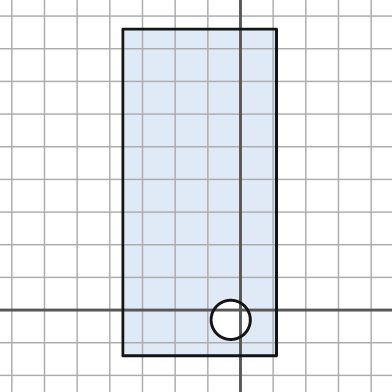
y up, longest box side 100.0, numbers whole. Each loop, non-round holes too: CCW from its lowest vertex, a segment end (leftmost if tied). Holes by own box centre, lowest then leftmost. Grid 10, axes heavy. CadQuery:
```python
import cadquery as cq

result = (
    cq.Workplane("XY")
    .moveTo(-36.0, -14.0)
    .lineTo(11.0, -14.0)
    .lineTo(11.0, 86.0)
    .lineTo(-36.0, 86.0)
    .close()
    .moveTo(-3.0, -3.0)
    .circle(6.0)
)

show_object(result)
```